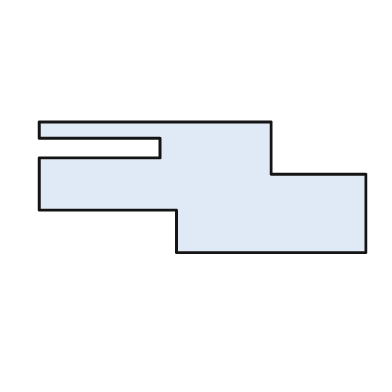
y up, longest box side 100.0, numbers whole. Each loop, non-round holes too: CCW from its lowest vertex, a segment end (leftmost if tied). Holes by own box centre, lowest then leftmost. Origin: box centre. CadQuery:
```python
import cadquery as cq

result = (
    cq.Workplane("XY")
    .moveTo(-8.0, -20.0)
    .lineTo(50.0, -20.0)
    .lineTo(50.0, 4.0)
    .lineTo(21.0, 4.0)
    .lineTo(21.0, 20.0)
    .lineTo(-50.0, 20.0)
    .lineTo(-50.0, 15.0)
    .lineTo(-13.0, 15.0)
    .lineTo(-13.0, 9.0)
    .lineTo(-50.0, 9.0)
    .lineTo(-50.0, -7.0)
    .lineTo(-8.0, -7.0)
    .close()
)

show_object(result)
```